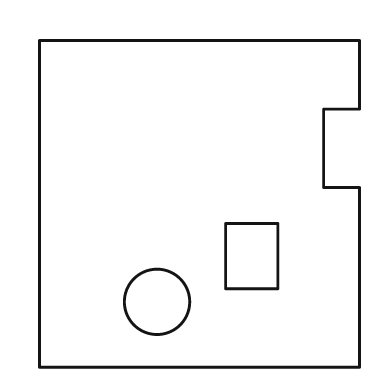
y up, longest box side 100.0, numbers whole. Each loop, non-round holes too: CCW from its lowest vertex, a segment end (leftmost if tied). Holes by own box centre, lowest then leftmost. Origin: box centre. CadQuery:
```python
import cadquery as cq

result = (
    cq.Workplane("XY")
    .moveTo(-49.0, -50.0)
    .lineTo(49.0, -50.0)
    .lineTo(49.0, 5.0)
    .lineTo(38.0, 5.0)
    .lineTo(38.0, 29.0)
    .lineTo(49.0, 29.0)
    .lineTo(49.0, 50.0)
    .lineTo(-49.0, 50.0)
    .close()
    .moveTo(-13.0, -30.0)
    .circle(10.0)
    .moveTo(8.0, -26.0)
    .lineTo(24.0, -26.0)
    .lineTo(24.0, -6.0)
    .lineTo(8.0, -6.0)
    .close()
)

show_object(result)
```